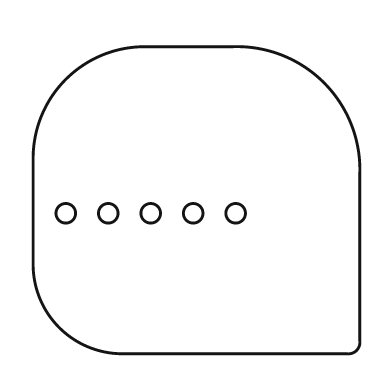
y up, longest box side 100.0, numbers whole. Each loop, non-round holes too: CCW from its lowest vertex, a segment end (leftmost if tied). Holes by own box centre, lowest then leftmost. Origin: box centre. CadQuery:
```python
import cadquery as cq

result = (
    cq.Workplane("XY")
    .moveTo(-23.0, -47.0)
    .lineTo(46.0, -47.0)
    .threePointArc((49.0, -46.0), (50.0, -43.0))
    .lineTo(50.0, 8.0)
    .threePointArc((39.0, 36.0), (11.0, 47.0))
    .lineTo(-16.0, 47.0)
    .threePointArc((-40.0, 37.0), (-50.0, 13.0))
    .lineTo(-50.0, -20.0)
    .threePointArc((-42.0, -39.0), (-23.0, -47.0))
    .close()
    .moveTo(-40.0, -4.0)
    .circle(3.0)
    .moveTo(-27.0, -4.0)
    .circle(3.0)
    .moveTo(-14.0, -4.0)
    .circle(3.0)
    .moveTo(-1.0, -4.0)
    .circle(3.0)
    .moveTo(12.0, -4.0)
    .circle(3.0)
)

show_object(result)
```